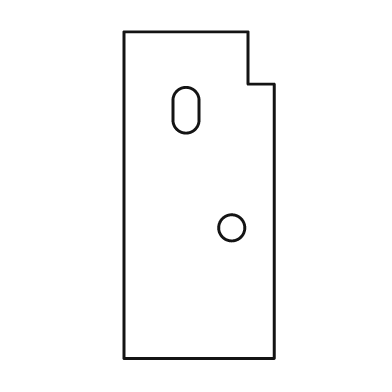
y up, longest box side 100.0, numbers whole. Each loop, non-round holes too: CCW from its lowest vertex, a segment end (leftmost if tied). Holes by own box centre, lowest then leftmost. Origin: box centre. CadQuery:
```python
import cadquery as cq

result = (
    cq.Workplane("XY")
    .moveTo(-23.0, -50.0)
    .lineTo(23.0, -50.0)
    .lineTo(23.0, 34.0)
    .lineTo(15.0, 34.0)
    .lineTo(15.0, 50.0)
    .lineTo(-23.0, 50.0)
    .close()
    .moveTo(10.0, -10.0)
    .circle(4.0)
    .moveTo(-8.0, 23.0)
    .threePointArc((-4.0, 19.0), (0.0, 23.0))
    .lineTo(0.0, 29.0)
    .threePointArc((-4.0, 33.0), (-8.0, 29.0))
    .close()
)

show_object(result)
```